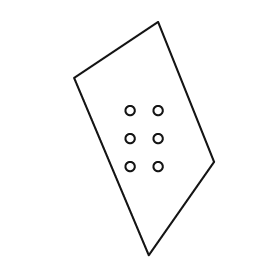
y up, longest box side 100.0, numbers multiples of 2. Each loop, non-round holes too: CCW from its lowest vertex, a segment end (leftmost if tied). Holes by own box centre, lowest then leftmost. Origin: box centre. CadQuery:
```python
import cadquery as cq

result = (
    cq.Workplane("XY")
    .moveTo(2.0, -50.0)
    .lineTo(30.0, -10.0)
    .lineTo(6.0, 50.0)
    .lineTo(-30.0, 26.0)
    .close()
    .moveTo(-6.0, -12.0)
    .circle(2.0)
    .moveTo(6.0, -12.0)
    .circle(2.0)
    .moveTo(-6.0, 0.0)
    .circle(2.0)
    .moveTo(6.0, 0.0)
    .circle(2.0)
    .moveTo(-6.0, 12.0)
    .circle(2.0)
    .moveTo(6.0, 12.0)
    .circle(2.0)
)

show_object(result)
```